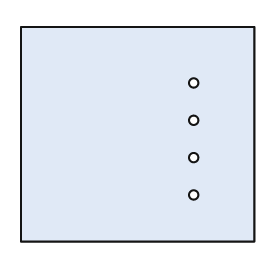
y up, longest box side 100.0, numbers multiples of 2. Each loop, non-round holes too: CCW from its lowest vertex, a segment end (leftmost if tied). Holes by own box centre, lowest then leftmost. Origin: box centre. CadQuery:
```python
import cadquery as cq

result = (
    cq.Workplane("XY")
    .moveTo(-50.0, -46.0)
    .lineTo(50.0, -46.0)
    .lineTo(50.0, 46.0)
    .lineTo(-50.0, 46.0)
    .close()
    .moveTo(24.0, -26.0)
    .circle(2.0)
    .moveTo(24.0, -10.0)
    .circle(2.0)
    .moveTo(24.0, 6.0)
    .circle(2.0)
    .moveTo(24.0, 22.0)
    .circle(2.0)
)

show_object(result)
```